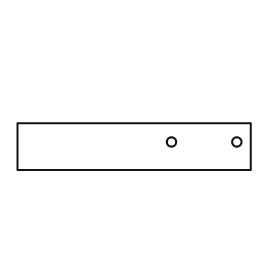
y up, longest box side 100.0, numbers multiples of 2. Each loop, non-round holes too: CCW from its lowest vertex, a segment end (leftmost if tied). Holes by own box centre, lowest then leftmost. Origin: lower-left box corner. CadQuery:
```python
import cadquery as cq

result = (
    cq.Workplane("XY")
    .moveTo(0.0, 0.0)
    .lineTo(100.0, 0.0)
    .lineTo(100.0, 20.0)
    .lineTo(0.0, 20.0)
    .close()
    .moveTo(66.0, 12.0)
    .circle(2.0)
    .moveTo(94.0, 12.0)
    .circle(2.0)
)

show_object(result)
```